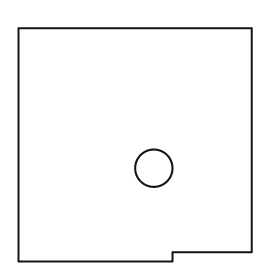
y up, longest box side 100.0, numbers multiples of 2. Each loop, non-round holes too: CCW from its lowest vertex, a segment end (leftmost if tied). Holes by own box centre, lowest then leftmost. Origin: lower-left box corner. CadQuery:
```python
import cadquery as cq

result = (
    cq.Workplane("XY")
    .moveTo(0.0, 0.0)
    .lineTo(66.0, 0.0)
    .lineTo(66.0, 4.0)
    .lineTo(100.0, 4.0)
    .lineTo(100.0, 100.0)
    .lineTo(0.0, 100.0)
    .close()
    .moveTo(58.0, 40.0)
    .circle(8.0)
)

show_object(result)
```